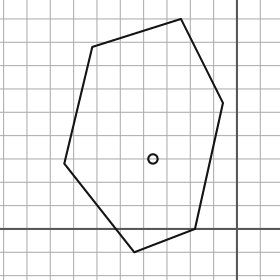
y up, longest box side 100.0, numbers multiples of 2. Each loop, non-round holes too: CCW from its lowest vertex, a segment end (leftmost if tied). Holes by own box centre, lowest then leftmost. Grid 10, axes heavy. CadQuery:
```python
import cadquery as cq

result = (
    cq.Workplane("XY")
    .moveTo(-44.0, -10.0)
    .lineTo(-18.0, 0.0)
    .lineTo(-6.0, 54.0)
    .lineTo(-24.0, 90.0)
    .lineTo(-62.0, 78.0)
    .lineTo(-74.0, 28.0)
    .close()
    .moveTo(-36.0, 30.0)
    .circle(2.0)
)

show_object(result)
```